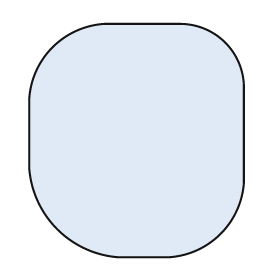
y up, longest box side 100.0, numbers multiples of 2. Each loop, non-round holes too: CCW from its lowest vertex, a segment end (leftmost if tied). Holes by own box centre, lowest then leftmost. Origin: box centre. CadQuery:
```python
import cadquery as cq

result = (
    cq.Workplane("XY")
    .moveTo(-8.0, -50.0)
    .lineTo(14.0, -50.0)
    .threePointArc((36.0, -40.0), (46.0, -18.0))
    .lineTo(46.0, 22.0)
    .threePointArc((38.0, 42.0), (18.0, 50.0))
    .lineTo(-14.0, 50.0)
    .threePointArc((-36.0, 40.0), (-46.0, 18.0))
    .lineTo(-46.0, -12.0)
    .threePointArc((-34.0, -38.0), (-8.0, -50.0))
    .close()
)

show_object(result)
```